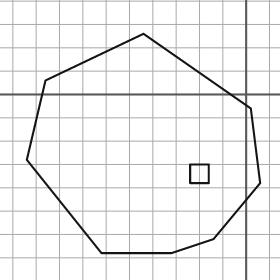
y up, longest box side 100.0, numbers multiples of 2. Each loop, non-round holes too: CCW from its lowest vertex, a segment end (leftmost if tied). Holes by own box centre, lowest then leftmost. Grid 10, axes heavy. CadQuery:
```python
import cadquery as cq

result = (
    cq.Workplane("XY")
    .moveTo(-62.0, -68.0)
    .lineTo(-32.0, -68.0)
    .lineTo(-14.0, -62.0)
    .lineTo(6.0, -38.0)
    .lineTo(2.0, -6.0)
    .lineTo(-44.0, 26.0)
    .lineTo(-86.0, 6.0)
    .lineTo(-94.0, -28.0)
    .close()
    .moveTo(-24.0, -38.0)
    .lineTo(-16.0, -38.0)
    .lineTo(-16.0, -30.0)
    .lineTo(-24.0, -30.0)
    .close()
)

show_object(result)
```